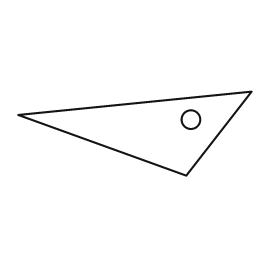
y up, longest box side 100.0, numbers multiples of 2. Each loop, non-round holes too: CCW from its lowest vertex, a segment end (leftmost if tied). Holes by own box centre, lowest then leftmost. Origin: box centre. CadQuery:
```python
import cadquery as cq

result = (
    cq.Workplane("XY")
    .moveTo(22.0, -18.0)
    .lineTo(50.0, 18.0)
    .lineTo(-50.0, 8.0)
    .close()
    .moveTo(24.0, 6.0)
    .circle(4.0)
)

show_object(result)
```